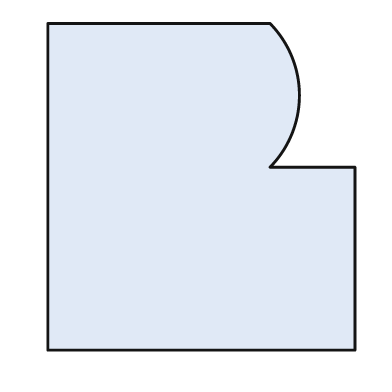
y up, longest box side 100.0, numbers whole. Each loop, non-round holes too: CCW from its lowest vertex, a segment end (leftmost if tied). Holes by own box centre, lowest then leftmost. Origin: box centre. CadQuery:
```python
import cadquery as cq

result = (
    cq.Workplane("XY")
    .moveTo(-47.0, -50.0)
    .lineTo(47.0, -50.0)
    .lineTo(47.0, 6.0)
    .lineTo(21.0, 6.0)
    .threePointArc((30.0, 28.0), (21.0, 50.0))
    .lineTo(-47.0, 50.0)
    .close()
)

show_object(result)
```